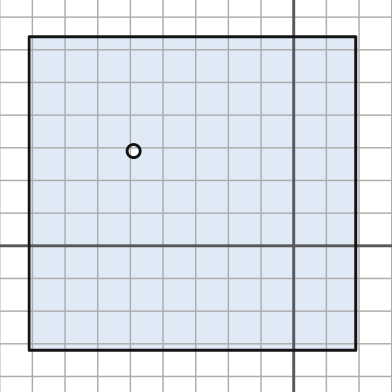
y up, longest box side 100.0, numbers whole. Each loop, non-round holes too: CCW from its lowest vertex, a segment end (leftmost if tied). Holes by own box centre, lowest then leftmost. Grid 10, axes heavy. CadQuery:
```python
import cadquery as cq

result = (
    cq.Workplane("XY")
    .moveTo(-81.0, -32.0)
    .lineTo(19.0, -32.0)
    .lineTo(19.0, 64.0)
    .lineTo(-81.0, 64.0)
    .close()
    .moveTo(-49.0, 29.0)
    .circle(2.0)
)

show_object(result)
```